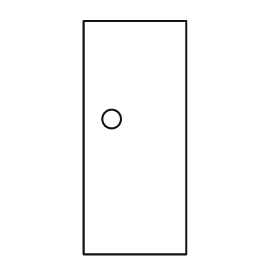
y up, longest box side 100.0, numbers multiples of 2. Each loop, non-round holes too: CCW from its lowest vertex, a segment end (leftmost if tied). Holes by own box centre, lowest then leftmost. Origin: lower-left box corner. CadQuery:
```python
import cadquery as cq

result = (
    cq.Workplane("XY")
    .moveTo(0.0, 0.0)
    .lineTo(44.0, 0.0)
    .lineTo(44.0, 100.0)
    .lineTo(0.0, 100.0)
    .close()
    .moveTo(12.0, 58.0)
    .circle(4.0)
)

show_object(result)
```